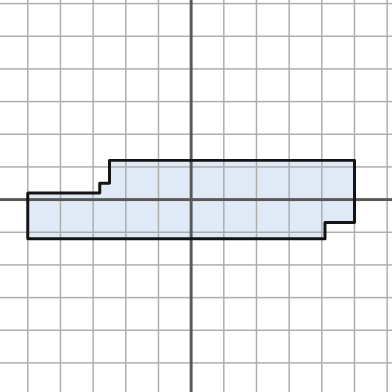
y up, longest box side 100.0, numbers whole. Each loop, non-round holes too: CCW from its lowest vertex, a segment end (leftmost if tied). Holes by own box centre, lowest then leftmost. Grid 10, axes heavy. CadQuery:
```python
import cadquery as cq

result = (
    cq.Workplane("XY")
    .moveTo(-50.0, -12.0)
    .lineTo(41.0, -12.0)
    .lineTo(41.0, -7.0)
    .lineTo(50.0, -7.0)
    .lineTo(50.0, 12.0)
    .lineTo(-25.0, 12.0)
    .lineTo(-25.0, 5.0)
    .lineTo(-28.0, 5.0)
    .lineTo(-28.0, 2.0)
    .lineTo(-50.0, 2.0)
    .close()
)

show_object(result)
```